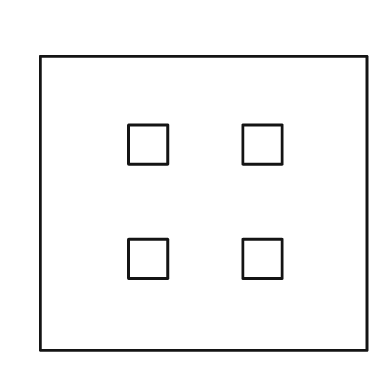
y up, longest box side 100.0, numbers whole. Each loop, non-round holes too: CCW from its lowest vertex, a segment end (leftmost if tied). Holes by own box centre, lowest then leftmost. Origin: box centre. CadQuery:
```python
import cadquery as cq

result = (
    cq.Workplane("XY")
    .moveTo(-50.0, -45.0)
    .lineTo(50.0, -45.0)
    .lineTo(50.0, 45.0)
    .lineTo(-50.0, 45.0)
    .close()
    .moveTo(-23.0, -23.0)
    .lineTo(-11.0, -23.0)
    .lineTo(-11.0, -11.0)
    .lineTo(-23.0, -11.0)
    .close()
    .moveTo(12.0, -23.0)
    .lineTo(24.0, -23.0)
    .lineTo(24.0, -11.0)
    .lineTo(12.0, -11.0)
    .close()
    .moveTo(-23.0, 12.0)
    .lineTo(-11.0, 12.0)
    .lineTo(-11.0, 24.0)
    .lineTo(-23.0, 24.0)
    .close()
    .moveTo(12.0, 12.0)
    .lineTo(24.0, 12.0)
    .lineTo(24.0, 24.0)
    .lineTo(12.0, 24.0)
    .close()
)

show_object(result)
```